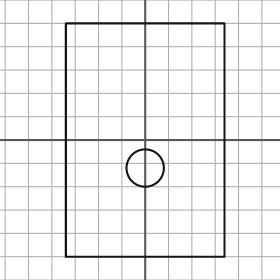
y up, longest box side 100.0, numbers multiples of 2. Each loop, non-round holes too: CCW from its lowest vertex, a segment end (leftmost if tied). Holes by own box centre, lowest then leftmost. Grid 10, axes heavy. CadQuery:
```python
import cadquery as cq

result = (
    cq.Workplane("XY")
    .moveTo(-34.0, -50.0)
    .lineTo(34.0, -50.0)
    .lineTo(34.0, 50.0)
    .lineTo(-34.0, 50.0)
    .close()
    .moveTo(0.0, -12.0)
    .circle(8.0)
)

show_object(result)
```